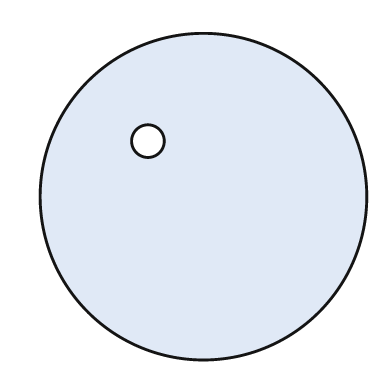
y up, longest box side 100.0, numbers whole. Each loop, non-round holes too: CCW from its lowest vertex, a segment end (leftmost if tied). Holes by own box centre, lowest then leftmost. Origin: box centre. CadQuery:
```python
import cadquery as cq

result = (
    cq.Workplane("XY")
    .moveTo(0.0, 0.0)
    .circle(50.0)
    .moveTo(-17.0, 17.0)
    .circle(5.0)
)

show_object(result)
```